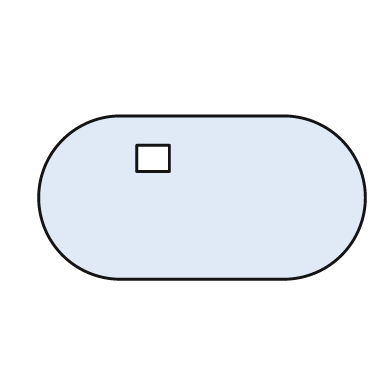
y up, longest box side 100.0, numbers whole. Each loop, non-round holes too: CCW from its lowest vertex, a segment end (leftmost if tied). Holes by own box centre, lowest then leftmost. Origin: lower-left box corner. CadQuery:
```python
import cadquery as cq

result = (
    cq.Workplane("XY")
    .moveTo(25.0, 0.0)
    .lineTo(75.0, 0.0)
    .threePointArc((100.0, 25.0), (75.0, 50.0))
    .lineTo(25.0, 50.0)
    .threePointArc((0.0, 25.0), (25.0, 0.0))
    .close()
    .moveTo(30.0, 33.0)
    .lineTo(40.0, 33.0)
    .lineTo(40.0, 41.0)
    .lineTo(30.0, 41.0)
    .close()
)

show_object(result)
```